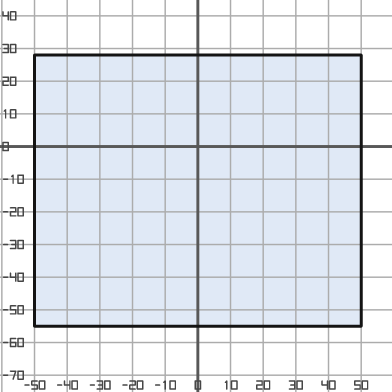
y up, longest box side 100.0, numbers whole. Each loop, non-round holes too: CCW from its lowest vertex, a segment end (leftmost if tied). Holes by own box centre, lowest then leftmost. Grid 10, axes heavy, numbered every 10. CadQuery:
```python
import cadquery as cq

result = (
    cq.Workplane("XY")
    .moveTo(-50.0, -55.0)
    .lineTo(50.0, -55.0)
    .lineTo(50.0, 28.0)
    .lineTo(-50.0, 28.0)
    .close()
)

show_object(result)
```